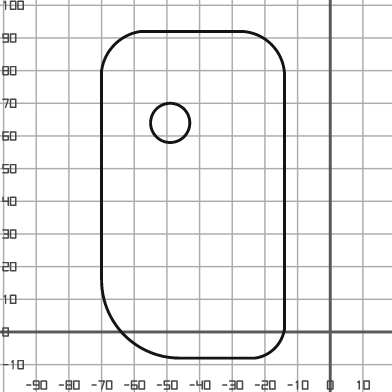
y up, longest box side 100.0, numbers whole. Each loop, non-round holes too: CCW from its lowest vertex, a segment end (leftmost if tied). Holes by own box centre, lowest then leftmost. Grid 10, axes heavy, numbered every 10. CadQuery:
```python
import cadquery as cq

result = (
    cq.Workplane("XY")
    .moveTo(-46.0, -8.0)
    .lineTo(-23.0, -8.0)
    .threePointArc((-17.0, -5.0), (-14.0, 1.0))
    .lineTo(-14.0, 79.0)
    .threePointArc((-18.0, 88.0), (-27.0, 92.0))
    .lineTo(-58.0, 92.0)
    .threePointArc((-66.0, 88.0), (-70.0, 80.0))
    .lineTo(-70.0, 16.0)
    .threePointArc((-63.0, -1.0), (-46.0, -8.0))
    .close()
    .moveTo(-49.0, 64.0)
    .circle(6.0)
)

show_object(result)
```